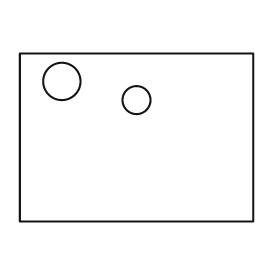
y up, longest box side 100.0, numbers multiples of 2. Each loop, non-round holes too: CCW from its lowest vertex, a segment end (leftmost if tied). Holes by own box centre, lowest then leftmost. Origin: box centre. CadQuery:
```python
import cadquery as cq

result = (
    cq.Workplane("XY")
    .moveTo(-50.0, -36.0)
    .lineTo(50.0, -36.0)
    .lineTo(50.0, 36.0)
    .lineTo(-50.0, 36.0)
    .close()
    .moveTo(0.0, 16.0)
    .circle(6.0)
    .moveTo(-32.0, 24.0)
    .circle(8.0)
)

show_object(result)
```